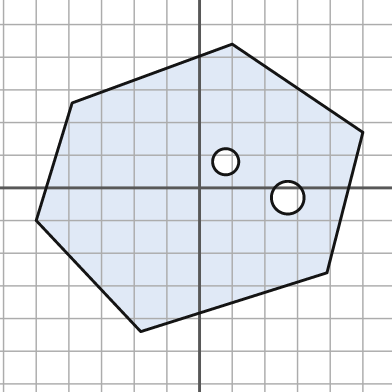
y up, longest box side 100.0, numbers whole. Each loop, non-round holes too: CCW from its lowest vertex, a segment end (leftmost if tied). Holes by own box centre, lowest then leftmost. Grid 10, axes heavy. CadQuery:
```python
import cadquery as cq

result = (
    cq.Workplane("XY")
    .moveTo(-18.0, -44.0)
    .lineTo(39.0, -26.0)
    .lineTo(50.0, 17.0)
    .lineTo(10.0, 44.0)
    .lineTo(-39.0, 26.0)
    .lineTo(-50.0, -10.0)
    .close()
    .moveTo(27.0, -3.0)
    .circle(5.0)
    .moveTo(8.0, 8.0)
    .circle(4.0)
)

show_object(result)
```